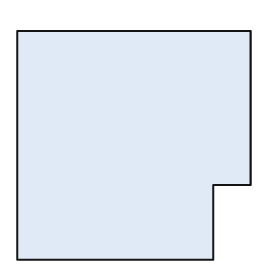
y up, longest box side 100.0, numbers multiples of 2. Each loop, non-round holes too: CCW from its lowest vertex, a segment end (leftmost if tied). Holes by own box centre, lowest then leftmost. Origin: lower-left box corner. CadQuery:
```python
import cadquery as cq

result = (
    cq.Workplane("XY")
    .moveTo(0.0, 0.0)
    .lineTo(84.0, 0.0)
    .lineTo(84.0, 32.0)
    .lineTo(100.0, 32.0)
    .lineTo(100.0, 98.0)
    .lineTo(0.0, 98.0)
    .close()
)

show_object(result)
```